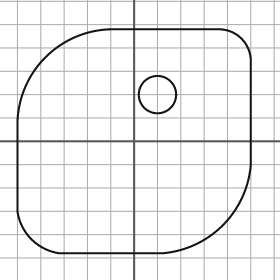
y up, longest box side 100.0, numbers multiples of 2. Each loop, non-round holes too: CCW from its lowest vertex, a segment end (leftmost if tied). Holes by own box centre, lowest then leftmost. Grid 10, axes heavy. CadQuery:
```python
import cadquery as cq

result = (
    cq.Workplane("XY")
    .moveTo(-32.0, -48.0)
    .lineTo(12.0, -48.0)
    .threePointArc((38.0, -36.0), (50.0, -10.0))
    .lineTo(50.0, 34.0)
    .threePointArc((46.0, 44.0), (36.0, 48.0))
    .lineTo(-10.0, 48.0)
    .threePointArc((-38.0, 36.0), (-50.0, 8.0))
    .lineTo(-50.0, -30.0)
    .threePointArc((-44.0, -42.0), (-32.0, -48.0))
    .close()
    .moveTo(10.0, 20.0)
    .circle(8.0)
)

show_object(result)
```